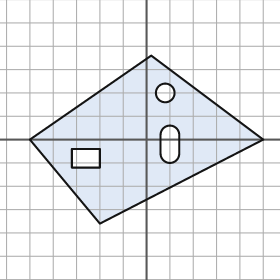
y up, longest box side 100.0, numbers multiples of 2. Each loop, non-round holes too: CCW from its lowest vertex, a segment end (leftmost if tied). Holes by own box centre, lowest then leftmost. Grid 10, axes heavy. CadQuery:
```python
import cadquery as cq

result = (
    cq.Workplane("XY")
    .moveTo(-20.0, -36.0)
    .lineTo(50.0, 0.0)
    .lineTo(2.0, 36.0)
    .lineTo(-50.0, 0.0)
    .close()
    .moveTo(-32.0, -12.0)
    .lineTo(-20.0, -12.0)
    .lineTo(-20.0, -4.0)
    .lineTo(-32.0, -4.0)
    .close()
    .moveTo(6.0, -6.0)
    .threePointArc((10.0, -10.0), (14.0, -6.0))
    .lineTo(14.0, 2.0)
    .threePointArc((10.0, 6.0), (6.0, 2.0))
    .close()
    .moveTo(8.0, 20.0)
    .circle(4.0)
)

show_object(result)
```